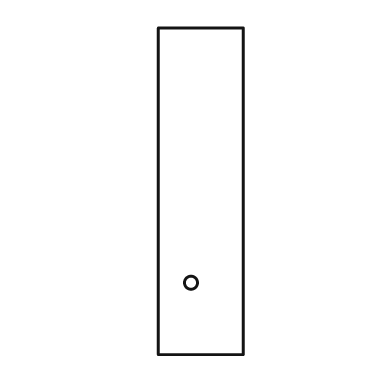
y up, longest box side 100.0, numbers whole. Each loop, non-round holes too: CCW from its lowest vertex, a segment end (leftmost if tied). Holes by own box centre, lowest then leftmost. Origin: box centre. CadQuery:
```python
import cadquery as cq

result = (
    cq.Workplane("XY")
    .moveTo(-13.0, -50.0)
    .lineTo(13.0, -50.0)
    .lineTo(13.0, 50.0)
    .lineTo(-13.0, 50.0)
    .close()
    .moveTo(-3.0, -28.0)
    .circle(2.0)
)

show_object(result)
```